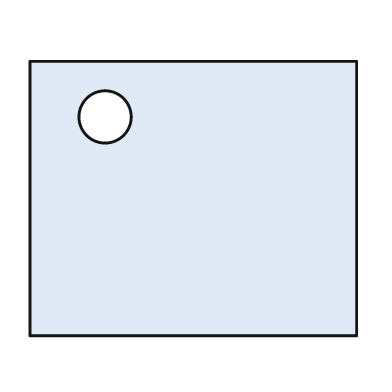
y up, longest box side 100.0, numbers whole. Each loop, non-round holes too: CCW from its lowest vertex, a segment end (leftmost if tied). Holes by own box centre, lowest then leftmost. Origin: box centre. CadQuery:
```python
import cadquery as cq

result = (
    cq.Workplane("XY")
    .moveTo(-50.0, -42.0)
    .lineTo(50.0, -42.0)
    .lineTo(50.0, 42.0)
    .lineTo(-50.0, 42.0)
    .close()
    .moveTo(-27.0, 25.0)
    .circle(8.0)
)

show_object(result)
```